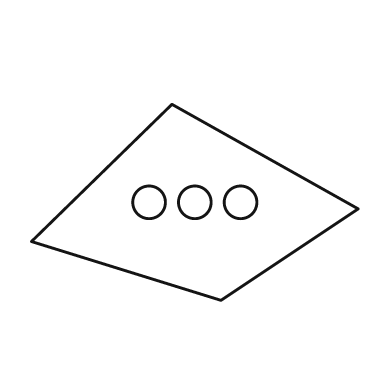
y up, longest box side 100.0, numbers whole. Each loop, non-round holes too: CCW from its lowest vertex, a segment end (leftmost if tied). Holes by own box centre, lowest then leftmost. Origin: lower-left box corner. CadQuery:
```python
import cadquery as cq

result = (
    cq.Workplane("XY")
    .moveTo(58.0, 0.0)
    .lineTo(100.0, 28.0)
    .lineTo(43.0, 60.0)
    .lineTo(0.0, 18.0)
    .close()
    .moveTo(36.0, 30.0)
    .circle(5.0)
    .moveTo(50.0, 30.0)
    .circle(5.0)
    .moveTo(64.0, 30.0)
    .circle(5.0)
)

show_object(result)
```